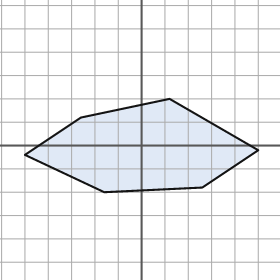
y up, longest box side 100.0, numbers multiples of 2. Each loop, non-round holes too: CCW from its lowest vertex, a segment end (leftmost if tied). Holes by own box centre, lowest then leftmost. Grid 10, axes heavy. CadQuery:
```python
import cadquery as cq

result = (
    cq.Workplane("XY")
    .moveTo(-16.0, -20.0)
    .lineTo(26.0, -18.0)
    .lineTo(50.0, -2.0)
    .lineTo(12.0, 20.0)
    .lineTo(-26.0, 12.0)
    .lineTo(-50.0, -4.0)
    .close()
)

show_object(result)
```